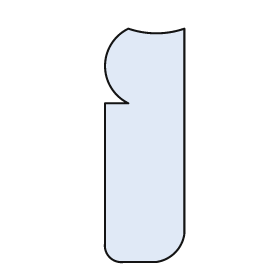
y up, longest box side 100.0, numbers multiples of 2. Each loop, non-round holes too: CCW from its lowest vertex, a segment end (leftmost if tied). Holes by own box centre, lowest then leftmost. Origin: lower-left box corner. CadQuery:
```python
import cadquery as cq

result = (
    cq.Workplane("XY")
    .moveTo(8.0, 0.0)
    .lineTo(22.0, 0.0)
    .threePointArc((30.0, 4.0), (34.0, 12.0))
    .lineTo(34.0, 100.0)
    .threePointArc((22.0, 98.0), (10.0, 100.0))
    .threePointArc((0.0, 84.0), (10.0, 68.0))
    .lineTo(0.0, 68.0)
    .lineTo(0.0, 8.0)
    .threePointArc((2.0, 2.0), (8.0, 0.0))
    .close()
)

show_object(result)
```